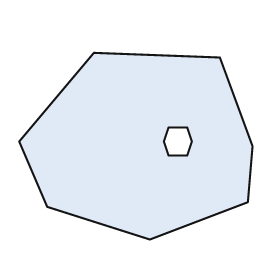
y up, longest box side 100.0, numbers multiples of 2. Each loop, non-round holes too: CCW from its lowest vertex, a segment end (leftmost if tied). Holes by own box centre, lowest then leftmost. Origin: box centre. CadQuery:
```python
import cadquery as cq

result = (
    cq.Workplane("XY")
    .moveTo(6.0, -40.0)
    .lineTo(48.0, -24.0)
    .lineTo(50.0, 0.0)
    .lineTo(36.0, 38.0)
    .lineTo(-18.0, 40.0)
    .lineTo(-50.0, 2.0)
    .lineTo(-38.0, -26.0)
    .close()
    .moveTo(14.0, -4.0)
    .lineTo(22.0, -4.0)
    .lineTo(24.0, 2.0)
    .lineTo(22.0, 8.0)
    .lineTo(14.0, 8.0)
    .lineTo(12.0, 2.0)
    .close()
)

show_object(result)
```